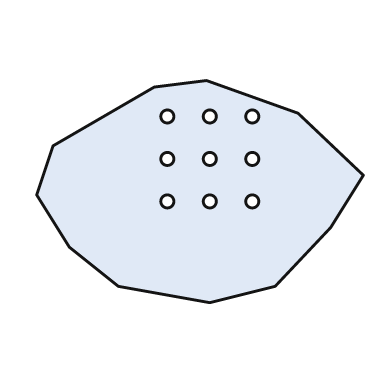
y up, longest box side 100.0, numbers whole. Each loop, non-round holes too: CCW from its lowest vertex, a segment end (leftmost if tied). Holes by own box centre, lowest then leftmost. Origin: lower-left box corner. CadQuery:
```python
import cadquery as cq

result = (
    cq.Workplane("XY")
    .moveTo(53.0, 0.0)
    .lineTo(73.0, 5.0)
    .lineTo(90.0, 23.0)
    .lineTo(100.0, 39.0)
    .lineTo(80.0, 58.0)
    .lineTo(52.0, 68.0)
    .lineTo(36.0, 66.0)
    .lineTo(5.0, 48.0)
    .lineTo(0.0, 33.0)
    .lineTo(10.0, 17.0)
    .lineTo(25.0, 5.0)
    .close()
    .moveTo(40.0, 31.0)
    .circle(2.0)
    .moveTo(53.0, 31.0)
    .circle(2.0)
    .moveTo(66.0, 31.0)
    .circle(2.0)
    .moveTo(40.0, 44.0)
    .circle(2.0)
    .moveTo(53.0, 44.0)
    .circle(2.0)
    .moveTo(66.0, 44.0)
    .circle(2.0)
    .moveTo(40.0, 57.0)
    .circle(2.0)
    .moveTo(53.0, 57.0)
    .circle(2.0)
    .moveTo(66.0, 57.0)
    .circle(2.0)
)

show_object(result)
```